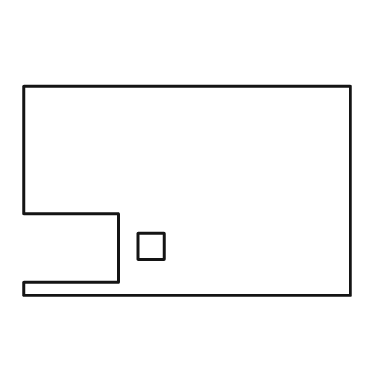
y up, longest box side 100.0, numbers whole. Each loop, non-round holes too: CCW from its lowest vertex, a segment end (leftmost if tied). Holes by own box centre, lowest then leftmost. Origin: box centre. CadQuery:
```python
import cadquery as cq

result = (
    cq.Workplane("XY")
    .moveTo(-50.0, -32.0)
    .lineTo(50.0, -32.0)
    .lineTo(50.0, 32.0)
    .lineTo(-50.0, 32.0)
    .lineTo(-50.0, -7.0)
    .lineTo(-21.0, -7.0)
    .lineTo(-21.0, -28.0)
    .lineTo(-50.0, -28.0)
    .close()
    .moveTo(-15.0, -21.0)
    .lineTo(-7.0, -21.0)
    .lineTo(-7.0, -13.0)
    .lineTo(-15.0, -13.0)
    .close()
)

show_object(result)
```